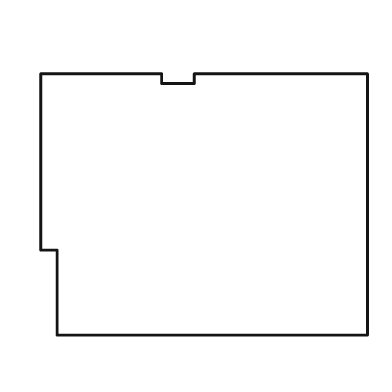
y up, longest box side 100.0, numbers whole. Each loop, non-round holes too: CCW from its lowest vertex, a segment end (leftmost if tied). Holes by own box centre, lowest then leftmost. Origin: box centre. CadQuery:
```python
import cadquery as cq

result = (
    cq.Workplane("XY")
    .moveTo(-45.0, -40.0)
    .lineTo(50.0, -40.0)
    .lineTo(50.0, 40.0)
    .lineTo(-3.0, 40.0)
    .lineTo(-3.0, 37.0)
    .lineTo(-13.0, 37.0)
    .lineTo(-13.0, 40.0)
    .lineTo(-50.0, 40.0)
    .lineTo(-50.0, -14.0)
    .lineTo(-45.0, -14.0)
    .close()
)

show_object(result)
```